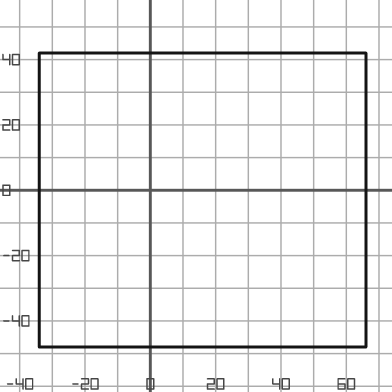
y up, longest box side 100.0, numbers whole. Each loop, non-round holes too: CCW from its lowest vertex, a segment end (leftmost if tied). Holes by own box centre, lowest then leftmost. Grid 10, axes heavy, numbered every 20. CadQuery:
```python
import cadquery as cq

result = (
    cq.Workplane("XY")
    .moveTo(-34.0, -48.0)
    .lineTo(66.0, -48.0)
    .lineTo(66.0, 42.0)
    .lineTo(-34.0, 42.0)
    .close()
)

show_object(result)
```